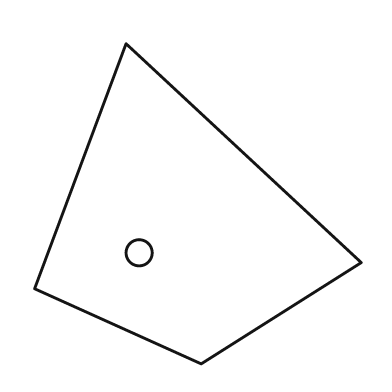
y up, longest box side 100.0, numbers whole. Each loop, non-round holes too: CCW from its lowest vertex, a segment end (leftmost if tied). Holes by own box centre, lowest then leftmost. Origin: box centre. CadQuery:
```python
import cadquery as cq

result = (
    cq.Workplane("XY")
    .moveTo(1.0, -49.0)
    .lineTo(50.0, -18.0)
    .lineTo(-22.0, 49.0)
    .lineTo(-50.0, -26.0)
    .close()
    .moveTo(-18.0, -15.0)
    .circle(4.0)
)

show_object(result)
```